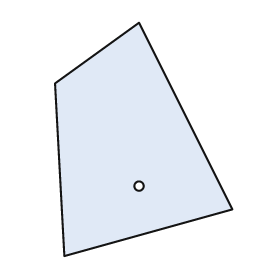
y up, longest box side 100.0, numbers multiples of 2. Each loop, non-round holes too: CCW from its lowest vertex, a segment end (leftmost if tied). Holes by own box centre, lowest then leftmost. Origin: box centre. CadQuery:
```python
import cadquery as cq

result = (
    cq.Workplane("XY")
    .moveTo(-34.0, -50.0)
    .lineTo(38.0, -30.0)
    .lineTo(-2.0, 50.0)
    .lineTo(-38.0, 24.0)
    .close()
    .moveTo(-2.0, -20.0)
    .circle(2.0)
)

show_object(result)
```